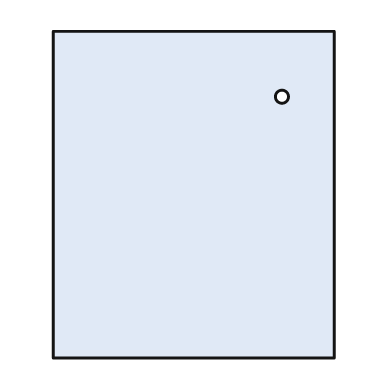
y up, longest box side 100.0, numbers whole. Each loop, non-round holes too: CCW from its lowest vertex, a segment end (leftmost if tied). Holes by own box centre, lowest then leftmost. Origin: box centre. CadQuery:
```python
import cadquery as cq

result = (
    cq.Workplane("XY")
    .moveTo(-43.0, -50.0)
    .lineTo(43.0, -50.0)
    .lineTo(43.0, 50.0)
    .lineTo(-43.0, 50.0)
    .close()
    .moveTo(27.0, 30.0)
    .circle(2.0)
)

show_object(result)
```